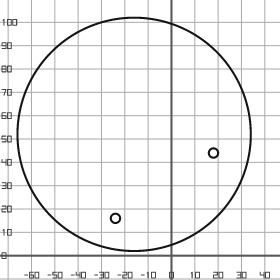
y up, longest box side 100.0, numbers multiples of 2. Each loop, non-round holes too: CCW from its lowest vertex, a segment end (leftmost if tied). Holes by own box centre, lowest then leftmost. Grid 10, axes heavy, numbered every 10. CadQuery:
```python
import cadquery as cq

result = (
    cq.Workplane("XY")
    .moveTo(-16.0, 52.0)
    .circle(50.0)
    .moveTo(-24.0, 16.0)
    .circle(2.0)
    .moveTo(18.0, 44.0)
    .circle(2.0)
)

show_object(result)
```